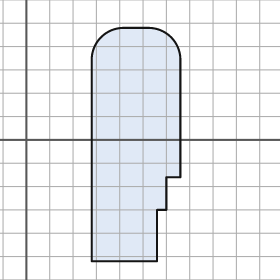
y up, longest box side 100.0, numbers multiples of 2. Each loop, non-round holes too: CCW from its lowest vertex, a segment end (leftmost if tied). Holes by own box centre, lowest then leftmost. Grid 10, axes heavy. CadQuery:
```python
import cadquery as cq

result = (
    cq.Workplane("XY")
    .moveTo(28.0, -52.0)
    .lineTo(56.0, -52.0)
    .lineTo(56.0, -30.0)
    .lineTo(60.0, -30.0)
    .lineTo(60.0, -16.0)
    .lineTo(66.0, -16.0)
    .lineTo(66.0, 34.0)
    .threePointArc((62.0, 44.0), (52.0, 48.0))
    .lineTo(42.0, 48.0)
    .threePointArc((32.0, 44.0), (28.0, 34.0))
    .close()
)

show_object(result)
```